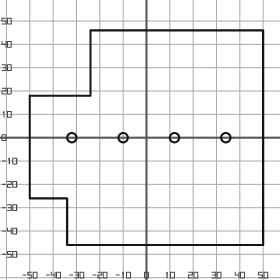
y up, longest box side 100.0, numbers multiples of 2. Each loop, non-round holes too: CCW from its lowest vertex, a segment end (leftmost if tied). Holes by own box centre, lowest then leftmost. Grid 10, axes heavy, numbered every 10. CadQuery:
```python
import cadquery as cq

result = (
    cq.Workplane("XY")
    .moveTo(-34.0, -46.0)
    .lineTo(50.0, -46.0)
    .lineTo(50.0, 46.0)
    .lineTo(-24.0, 46.0)
    .lineTo(-24.0, 18.0)
    .lineTo(-50.0, 18.0)
    .lineTo(-50.0, -26.0)
    .lineTo(-34.0, -26.0)
    .close()
    .moveTo(-32.0, 0.0)
    .circle(2.0)
    .moveTo(-10.0, 0.0)
    .circle(2.0)
    .moveTo(12.0, 0.0)
    .circle(2.0)
    .moveTo(34.0, 0.0)
    .circle(2.0)
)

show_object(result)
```